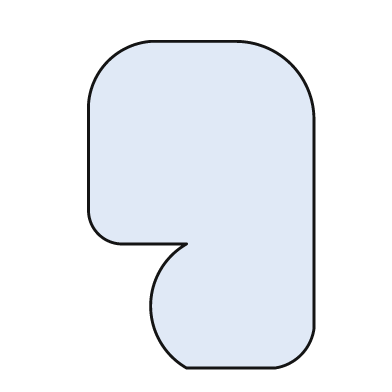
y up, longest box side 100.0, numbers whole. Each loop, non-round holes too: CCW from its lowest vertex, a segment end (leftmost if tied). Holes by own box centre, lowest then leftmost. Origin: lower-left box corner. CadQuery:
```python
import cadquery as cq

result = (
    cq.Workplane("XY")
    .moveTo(30.0, 0.0)
    .lineTo(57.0, 0.0)
    .threePointArc((65.0, 4.0), (69.0, 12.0))
    .lineTo(69.0, 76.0)
    .threePointArc((62.0, 93.0), (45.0, 100.0))
    .lineTo(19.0, 100.0)
    .threePointArc((6.0, 94.0), (0.0, 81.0))
    .lineTo(0.0, 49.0)
    .threePointArc((3.0, 41.0), (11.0, 38.0))
    .lineTo(30.0, 38.0)
    .threePointArc((19.0, 19.0), (30.0, 0.0))
    .close()
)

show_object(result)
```